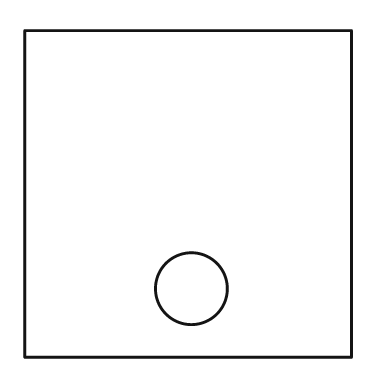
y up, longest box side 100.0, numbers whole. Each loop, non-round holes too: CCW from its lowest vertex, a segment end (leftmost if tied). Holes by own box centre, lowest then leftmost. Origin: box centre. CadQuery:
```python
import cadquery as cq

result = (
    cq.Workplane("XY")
    .moveTo(-50.0, -50.0)
    .lineTo(50.0, -50.0)
    .lineTo(50.0, 50.0)
    .lineTo(-50.0, 50.0)
    .close()
    .moveTo(1.0, -29.0)
    .circle(11.0)
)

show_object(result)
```